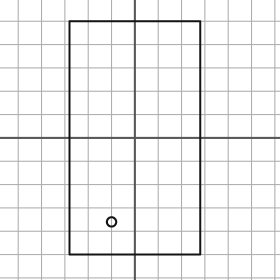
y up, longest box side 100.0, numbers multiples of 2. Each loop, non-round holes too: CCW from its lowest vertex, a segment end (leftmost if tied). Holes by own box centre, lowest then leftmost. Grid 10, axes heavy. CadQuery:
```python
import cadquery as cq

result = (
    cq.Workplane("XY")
    .moveTo(-28.0, -50.0)
    .lineTo(28.0, -50.0)
    .lineTo(28.0, 50.0)
    .lineTo(-28.0, 50.0)
    .close()
    .moveTo(-10.0, -36.0)
    .circle(2.0)
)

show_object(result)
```